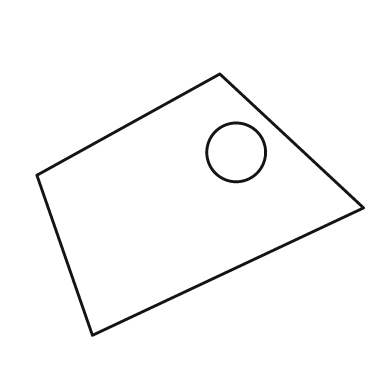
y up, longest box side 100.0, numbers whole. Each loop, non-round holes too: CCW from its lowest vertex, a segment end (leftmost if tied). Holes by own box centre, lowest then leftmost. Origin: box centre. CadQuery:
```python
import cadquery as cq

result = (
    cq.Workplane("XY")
    .moveTo(-33.0, -40.0)
    .lineTo(50.0, -1.0)
    .lineTo(6.0, 40.0)
    .lineTo(-50.0, 9.0)
    .close()
    .moveTo(11.0, 16.0)
    .circle(9.0)
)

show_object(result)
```